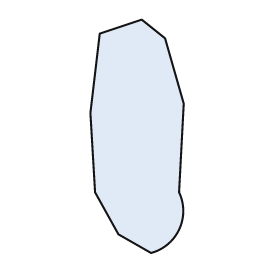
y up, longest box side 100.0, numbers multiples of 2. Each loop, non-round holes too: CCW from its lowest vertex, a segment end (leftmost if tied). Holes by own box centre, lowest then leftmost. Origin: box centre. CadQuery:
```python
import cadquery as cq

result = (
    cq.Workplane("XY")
    .moveTo(6.0, -50.0)
    .threePointArc((18.0, -40.0), (18.0, -24.0))
    .lineTo(20.0, 14.0)
    .lineTo(12.0, 42.0)
    .lineTo(2.0, 50.0)
    .lineTo(-16.0, 44.0)
    .lineTo(-20.0, 10.0)
    .lineTo(-18.0, -24.0)
    .lineTo(-8.0, -42.0)
    .close()
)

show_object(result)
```